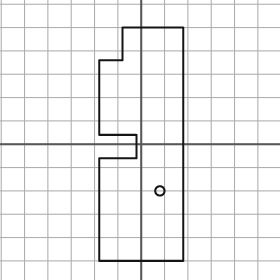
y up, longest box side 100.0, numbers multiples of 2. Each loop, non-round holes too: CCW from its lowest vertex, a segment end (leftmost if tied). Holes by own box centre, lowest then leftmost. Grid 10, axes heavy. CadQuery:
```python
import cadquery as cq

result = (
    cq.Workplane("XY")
    .moveTo(-18.0, -50.0)
    .lineTo(18.0, -50.0)
    .lineTo(18.0, 50.0)
    .lineTo(-8.0, 50.0)
    .lineTo(-8.0, 36.0)
    .lineTo(-18.0, 36.0)
    .lineTo(-18.0, 4.0)
    .lineTo(-2.0, 4.0)
    .lineTo(-2.0, -6.0)
    .lineTo(-18.0, -6.0)
    .close()
    .moveTo(8.0, -20.0)
    .circle(2.0)
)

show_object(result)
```